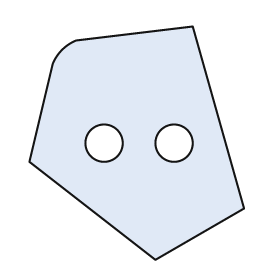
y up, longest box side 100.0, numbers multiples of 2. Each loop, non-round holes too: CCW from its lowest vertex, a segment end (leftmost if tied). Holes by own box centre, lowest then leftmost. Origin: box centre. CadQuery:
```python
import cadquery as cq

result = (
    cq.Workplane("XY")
    .moveTo(8.0, -50.0)
    .lineTo(46.0, -28.0)
    .lineTo(24.0, 50.0)
    .lineTo(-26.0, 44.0)
    .threePointArc((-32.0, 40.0), (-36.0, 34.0))
    .lineTo(-46.0, -8.0)
    .close()
    .moveTo(-14.0, 0.0)
    .circle(8.0)
    .moveTo(16.0, 0.0)
    .circle(8.0)
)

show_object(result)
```